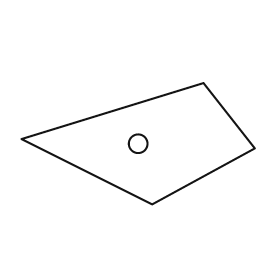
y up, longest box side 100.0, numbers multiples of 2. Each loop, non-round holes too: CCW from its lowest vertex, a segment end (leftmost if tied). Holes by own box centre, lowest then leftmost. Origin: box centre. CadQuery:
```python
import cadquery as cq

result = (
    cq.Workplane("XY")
    .moveTo(6.0, -26.0)
    .lineTo(50.0, -2.0)
    .lineTo(28.0, 26.0)
    .lineTo(-50.0, 2.0)
    .close()
    .moveTo(0.0, 0.0)
    .circle(4.0)
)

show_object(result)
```